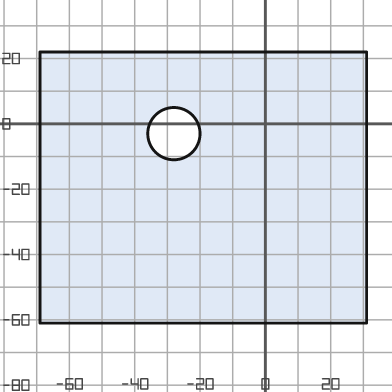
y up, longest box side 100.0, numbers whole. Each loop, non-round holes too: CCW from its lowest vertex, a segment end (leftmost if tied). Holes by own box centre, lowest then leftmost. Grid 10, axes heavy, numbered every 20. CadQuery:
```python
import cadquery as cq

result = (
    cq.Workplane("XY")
    .moveTo(-69.0, -61.0)
    .lineTo(31.0, -61.0)
    .lineTo(31.0, 22.0)
    .lineTo(-69.0, 22.0)
    .close()
    .moveTo(-28.0, -3.0)
    .circle(8.0)
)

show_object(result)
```